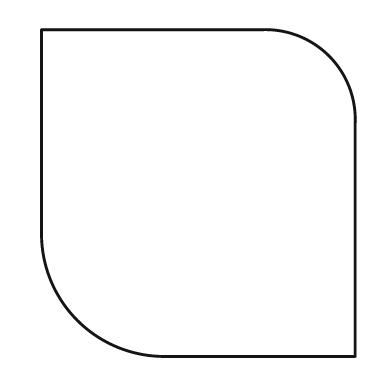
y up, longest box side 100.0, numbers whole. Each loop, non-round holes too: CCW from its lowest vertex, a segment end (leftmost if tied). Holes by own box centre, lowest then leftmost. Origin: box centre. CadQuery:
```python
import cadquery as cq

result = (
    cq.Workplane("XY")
    .moveTo(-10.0, -50.0)
    .lineTo(48.0, -50.0)
    .lineTo(48.0, 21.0)
    .threePointArc((40.0, 42.0), (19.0, 50.0))
    .lineTo(-48.0, 50.0)
    .lineTo(-48.0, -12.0)
    .threePointArc((-37.0, -39.0), (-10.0, -50.0))
    .close()
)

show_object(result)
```